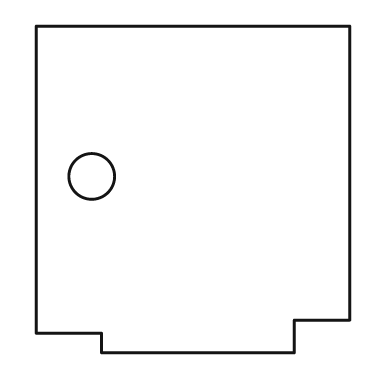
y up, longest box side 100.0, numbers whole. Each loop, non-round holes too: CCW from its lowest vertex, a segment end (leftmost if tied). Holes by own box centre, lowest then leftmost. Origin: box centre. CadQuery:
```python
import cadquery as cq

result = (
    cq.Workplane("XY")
    .moveTo(-28.0, -50.0)
    .lineTo(31.0, -50.0)
    .lineTo(31.0, -40.0)
    .lineTo(48.0, -40.0)
    .lineTo(48.0, 50.0)
    .lineTo(-48.0, 50.0)
    .lineTo(-48.0, -44.0)
    .lineTo(-28.0, -44.0)
    .close()
    .moveTo(-31.0, 4.0)
    .circle(7.0)
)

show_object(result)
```